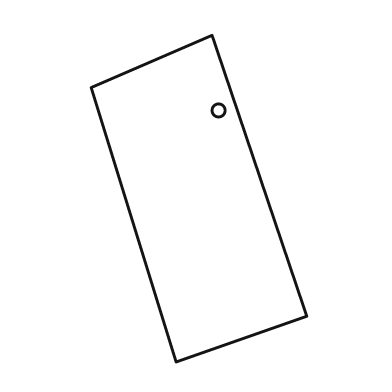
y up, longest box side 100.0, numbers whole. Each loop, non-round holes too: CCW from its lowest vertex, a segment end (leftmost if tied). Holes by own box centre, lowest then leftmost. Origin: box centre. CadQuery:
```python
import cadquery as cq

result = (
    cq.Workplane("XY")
    .moveTo(-7.0, -50.0)
    .lineTo(33.0, -36.0)
    .lineTo(4.0, 50.0)
    .lineTo(-33.0, 34.0)
    .close()
    .moveTo(6.0, 27.0)
    .circle(2.0)
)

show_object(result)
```